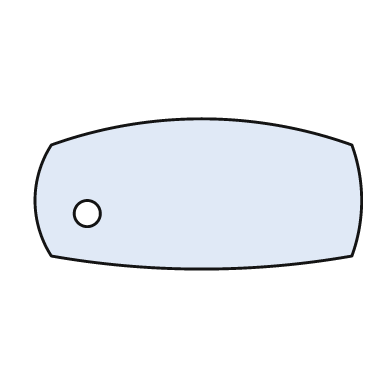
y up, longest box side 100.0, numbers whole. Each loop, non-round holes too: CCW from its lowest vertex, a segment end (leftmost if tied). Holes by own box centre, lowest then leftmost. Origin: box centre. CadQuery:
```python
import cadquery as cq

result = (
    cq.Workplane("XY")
    .moveTo(-45.0, -19.0)
    .threePointArc((1.0, -23.0), (47.0, -19.0))
    .threePointArc((50.0, -2.0), (47.0, 15.0))
    .threePointArc((1.0, 23.0), (-45.0, 15.0))
    .threePointArc((-50.0, -2.0), (-45.0, -19.0))
    .close()
    .moveTo(-34.0, -6.0)
    .circle(4.0)
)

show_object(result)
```